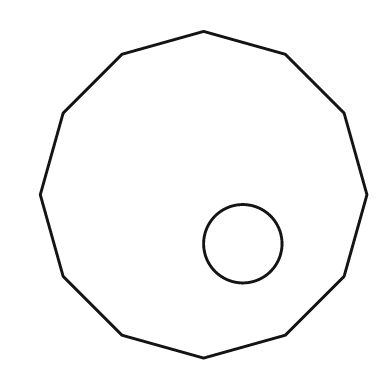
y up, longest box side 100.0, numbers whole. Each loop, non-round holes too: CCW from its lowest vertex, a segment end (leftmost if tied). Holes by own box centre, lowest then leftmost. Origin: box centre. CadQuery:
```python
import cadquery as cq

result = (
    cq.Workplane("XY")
    .moveTo(0.0, -50.0)
    .lineTo(25.0, -43.0)
    .lineTo(43.0, -25.0)
    .lineTo(50.0, 0.0)
    .lineTo(43.0, 25.0)
    .lineTo(25.0, 43.0)
    .lineTo(0.0, 50.0)
    .lineTo(-25.0, 43.0)
    .lineTo(-43.0, 25.0)
    .lineTo(-50.0, 0.0)
    .lineTo(-43.0, -25.0)
    .lineTo(-25.0, -43.0)
    .close()
    .moveTo(12.0, -15.0)
    .circle(12.0)
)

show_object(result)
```